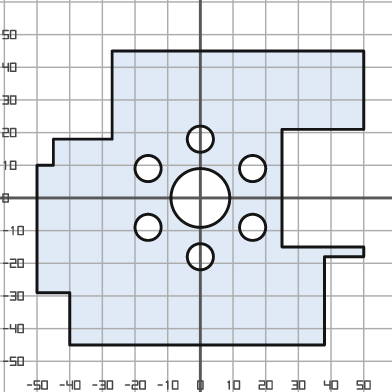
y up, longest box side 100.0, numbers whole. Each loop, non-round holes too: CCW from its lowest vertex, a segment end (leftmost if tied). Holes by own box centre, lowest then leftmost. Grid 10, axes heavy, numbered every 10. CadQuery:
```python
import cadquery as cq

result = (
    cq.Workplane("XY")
    .moveTo(-40.0, -45.0)
    .lineTo(38.0, -45.0)
    .lineTo(38.0, -18.0)
    .lineTo(50.0, -18.0)
    .lineTo(50.0, -15.0)
    .lineTo(25.0, -15.0)
    .lineTo(25.0, 21.0)
    .lineTo(50.0, 21.0)
    .lineTo(50.0, 45.0)
    .lineTo(-27.0, 45.0)
    .lineTo(-27.0, 18.0)
    .lineTo(-45.0, 18.0)
    .lineTo(-45.0, 10.0)
    .lineTo(-50.0, 10.0)
    .lineTo(-50.0, -29.0)
    .lineTo(-40.0, -29.0)
    .close()
    .moveTo(0.0, -18.0)
    .circle(4.0)
    .moveTo(-16.0, -9.0)
    .circle(4.0)
    .moveTo(16.0, -9.0)
    .circle(4.0)
    .moveTo(0.0, 0.0)
    .circle(9.0)
    .moveTo(-16.0, 9.0)
    .circle(4.0)
    .moveTo(16.0, 9.0)
    .circle(4.0)
    .moveTo(0.0, 18.0)
    .circle(4.0)
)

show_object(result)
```